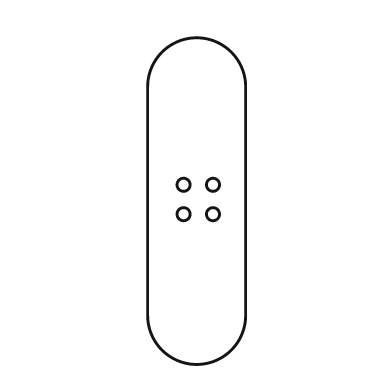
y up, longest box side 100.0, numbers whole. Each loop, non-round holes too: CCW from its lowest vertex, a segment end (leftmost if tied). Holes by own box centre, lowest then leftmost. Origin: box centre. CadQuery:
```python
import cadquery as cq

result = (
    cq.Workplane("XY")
    .moveTo(-15.0, -35.0)
    .threePointArc((0.0, -50.0), (15.0, -35.0))
    .lineTo(15.0, 35.0)
    .threePointArc((0.0, 50.0), (-15.0, 35.0))
    .close()
    .moveTo(-4.0, -4.0)
    .circle(2.0)
    .moveTo(5.0, -4.0)
    .circle(2.0)
    .moveTo(-4.0, 5.0)
    .circle(2.0)
    .moveTo(5.0, 5.0)
    .circle(2.0)
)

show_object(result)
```